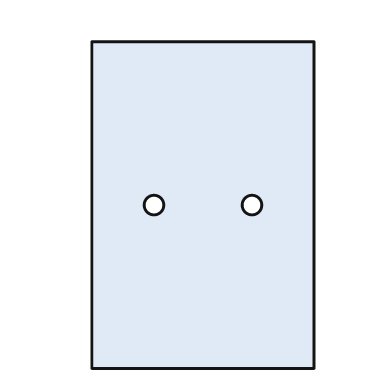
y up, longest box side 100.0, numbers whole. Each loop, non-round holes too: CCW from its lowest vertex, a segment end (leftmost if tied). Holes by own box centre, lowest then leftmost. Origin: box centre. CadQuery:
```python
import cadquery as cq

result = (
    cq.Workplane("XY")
    .moveTo(-34.0, -50.0)
    .lineTo(34.0, -50.0)
    .lineTo(34.0, 50.0)
    .lineTo(-34.0, 50.0)
    .close()
    .moveTo(-15.0, 0.0)
    .circle(3.0)
    .moveTo(15.0, 0.0)
    .circle(3.0)
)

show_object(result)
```